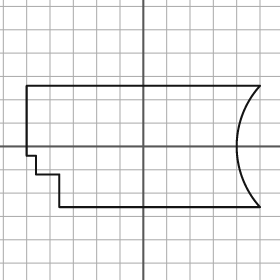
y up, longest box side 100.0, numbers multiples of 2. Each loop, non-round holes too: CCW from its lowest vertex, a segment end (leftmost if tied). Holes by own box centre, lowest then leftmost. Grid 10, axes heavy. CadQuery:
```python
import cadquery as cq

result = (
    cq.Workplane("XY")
    .moveTo(-36.0, -26.0)
    .lineTo(50.0, -26.0)
    .threePointArc((40.0, 0.0), (50.0, 26.0))
    .lineTo(-50.0, 26.0)
    .lineTo(-50.0, -4.0)
    .lineTo(-46.0, -4.0)
    .lineTo(-46.0, -12.0)
    .lineTo(-36.0, -12.0)
    .close()
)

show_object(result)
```